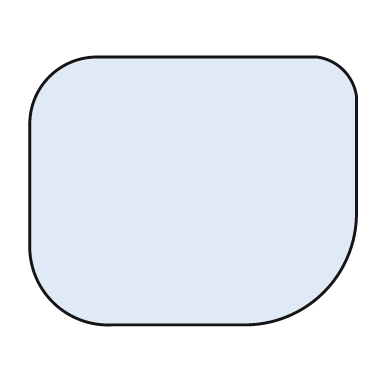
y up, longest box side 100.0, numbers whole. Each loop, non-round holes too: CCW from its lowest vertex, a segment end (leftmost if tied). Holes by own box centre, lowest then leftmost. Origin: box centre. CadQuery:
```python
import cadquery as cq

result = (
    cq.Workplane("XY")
    .moveTo(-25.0, -41.0)
    .lineTo(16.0, -41.0)
    .threePointArc((40.0, -31.0), (50.0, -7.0))
    .lineTo(50.0, 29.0)
    .threePointArc((46.0, 37.0), (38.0, 41.0))
    .lineTo(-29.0, 41.0)
    .threePointArc((-44.0, 35.0), (-50.0, 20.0))
    .lineTo(-50.0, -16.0)
    .threePointArc((-43.0, -34.0), (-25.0, -41.0))
    .close()
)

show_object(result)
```